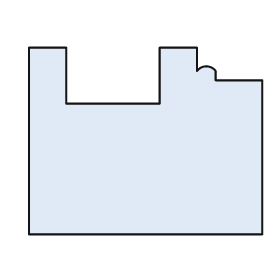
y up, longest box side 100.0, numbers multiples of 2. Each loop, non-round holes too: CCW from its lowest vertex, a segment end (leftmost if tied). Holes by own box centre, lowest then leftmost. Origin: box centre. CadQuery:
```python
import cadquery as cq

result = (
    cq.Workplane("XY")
    .moveTo(-50.0, -40.0)
    .lineTo(50.0, -40.0)
    .lineTo(50.0, 26.0)
    .lineTo(30.0, 26.0)
    .lineTo(30.0, 30.0)
    .threePointArc((26.0, 32.0), (22.0, 30.0))
    .lineTo(22.0, 40.0)
    .lineTo(6.0, 40.0)
    .lineTo(6.0, 16.0)
    .lineTo(-34.0, 16.0)
    .lineTo(-34.0, 40.0)
    .lineTo(-50.0, 40.0)
    .close()
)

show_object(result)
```